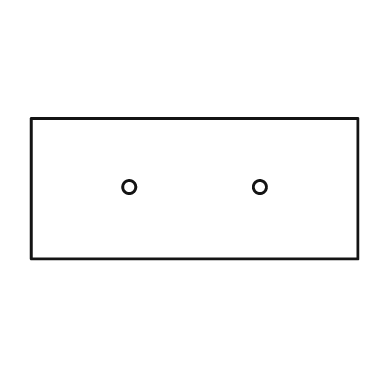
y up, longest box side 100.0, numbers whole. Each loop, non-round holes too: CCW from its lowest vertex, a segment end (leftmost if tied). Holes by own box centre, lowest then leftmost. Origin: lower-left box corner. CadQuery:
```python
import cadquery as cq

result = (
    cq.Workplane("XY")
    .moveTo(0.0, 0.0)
    .lineTo(100.0, 0.0)
    .lineTo(100.0, 43.0)
    .lineTo(0.0, 43.0)
    .close()
    .moveTo(30.0, 22.0)
    .circle(2.0)
    .moveTo(70.0, 22.0)
    .circle(2.0)
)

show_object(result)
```